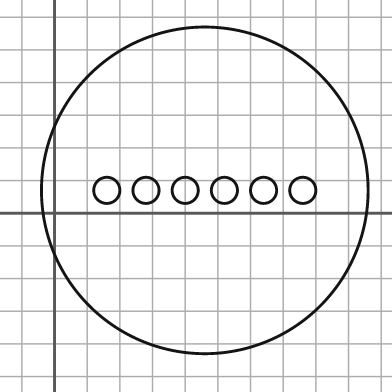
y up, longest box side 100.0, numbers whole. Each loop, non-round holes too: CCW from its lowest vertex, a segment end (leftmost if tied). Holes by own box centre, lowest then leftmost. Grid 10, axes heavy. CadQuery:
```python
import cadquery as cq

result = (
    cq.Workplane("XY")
    .moveTo(46.0, 7.0)
    .circle(50.0)
    .moveTo(16.0, 7.0)
    .circle(4.0)
    .moveTo(28.0, 7.0)
    .circle(4.0)
    .moveTo(40.0, 7.0)
    .circle(4.0)
    .moveTo(52.0, 7.0)
    .circle(4.0)
    .moveTo(64.0, 7.0)
    .circle(4.0)
    .moveTo(76.0, 7.0)
    .circle(4.0)
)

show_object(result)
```